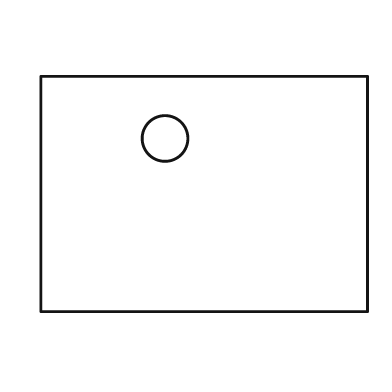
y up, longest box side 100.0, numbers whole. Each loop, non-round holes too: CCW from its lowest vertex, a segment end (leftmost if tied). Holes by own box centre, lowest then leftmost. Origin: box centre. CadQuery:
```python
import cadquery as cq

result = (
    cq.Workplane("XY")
    .moveTo(-50.0, -36.0)
    .lineTo(50.0, -36.0)
    .lineTo(50.0, 36.0)
    .lineTo(-50.0, 36.0)
    .close()
    .moveTo(-12.0, 17.0)
    .circle(7.0)
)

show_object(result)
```